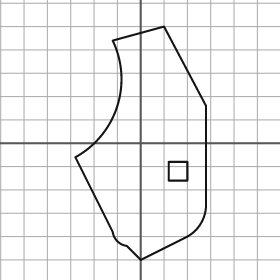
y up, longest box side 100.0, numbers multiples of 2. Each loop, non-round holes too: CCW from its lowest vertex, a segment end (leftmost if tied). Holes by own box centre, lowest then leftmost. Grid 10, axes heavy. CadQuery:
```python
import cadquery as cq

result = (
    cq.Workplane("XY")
    .moveTo(0.0, -50.0)
    .lineTo(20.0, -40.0)
    .threePointArc((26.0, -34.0), (28.0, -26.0))
    .lineTo(28.0, 16.0)
    .lineTo(10.0, 50.0)
    .lineTo(-12.0, 44.0)
    .threePointArc((-10.0, 16.0), (-28.0, -6.0))
    .lineTo(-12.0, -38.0)
    .threePointArc((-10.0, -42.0), (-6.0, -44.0))
    .close()
    .moveTo(12.0, -16.0)
    .lineTo(20.0, -16.0)
    .lineTo(20.0, -8.0)
    .lineTo(12.0, -8.0)
    .close()
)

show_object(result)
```